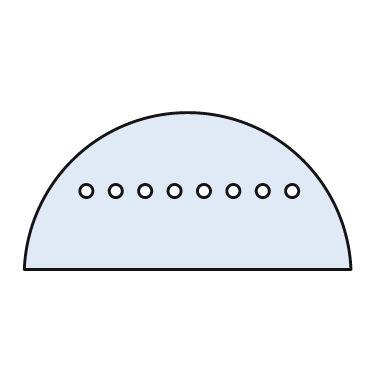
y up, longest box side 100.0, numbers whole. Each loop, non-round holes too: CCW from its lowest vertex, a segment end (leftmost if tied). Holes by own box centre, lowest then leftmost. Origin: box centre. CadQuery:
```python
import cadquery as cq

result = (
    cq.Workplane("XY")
    .moveTo(-50.0, -24.0)
    .lineTo(50.0, -24.0)
    .threePointArc((0.0, 24.0), (-50.0, -24.0))
    .close()
    .moveTo(-31.0, 0.0)
    .circle(2.0)
    .moveTo(-22.0, 0.0)
    .circle(2.0)
    .moveTo(-13.0, 0.0)
    .circle(2.0)
    .moveTo(-4.0, 0.0)
    .circle(2.0)
    .moveTo(5.0, 0.0)
    .circle(2.0)
    .moveTo(14.0, 0.0)
    .circle(2.0)
    .moveTo(23.0, 0.0)
    .circle(2.0)
    .moveTo(32.0, 0.0)
    .circle(2.0)
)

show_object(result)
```